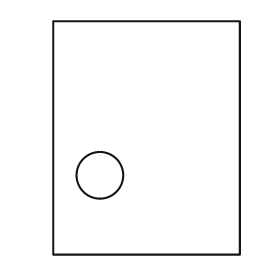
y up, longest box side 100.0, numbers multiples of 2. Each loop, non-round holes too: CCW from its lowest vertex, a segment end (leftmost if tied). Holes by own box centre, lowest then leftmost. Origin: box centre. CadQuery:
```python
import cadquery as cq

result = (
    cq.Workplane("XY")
    .moveTo(-40.0, -50.0)
    .lineTo(40.0, -50.0)
    .lineTo(40.0, 50.0)
    .lineTo(-40.0, 50.0)
    .close()
    .moveTo(-20.0, -16.0)
    .circle(10.0)
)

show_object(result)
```